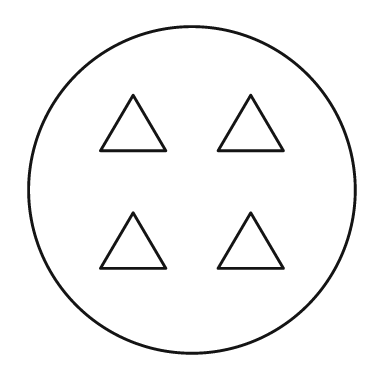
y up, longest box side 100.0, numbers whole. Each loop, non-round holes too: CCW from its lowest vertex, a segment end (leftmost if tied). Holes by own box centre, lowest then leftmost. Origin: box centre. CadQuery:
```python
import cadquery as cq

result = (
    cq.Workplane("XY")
    .moveTo(0.0, 0.0)
    .circle(50.0)
    .moveTo(-28.0, -24.0)
    .lineTo(-8.0, -24.0)
    .lineTo(-18.0, -7.0)
    .close()
    .moveTo(8.0, -24.0)
    .lineTo(28.0, -24.0)
    .lineTo(18.0, -7.0)
    .close()
    .moveTo(-28.0, 12.0)
    .lineTo(-8.0, 12.0)
    .lineTo(-18.0, 29.0)
    .close()
    .moveTo(8.0, 12.0)
    .lineTo(28.0, 12.0)
    .lineTo(18.0, 29.0)
    .close()
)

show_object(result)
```